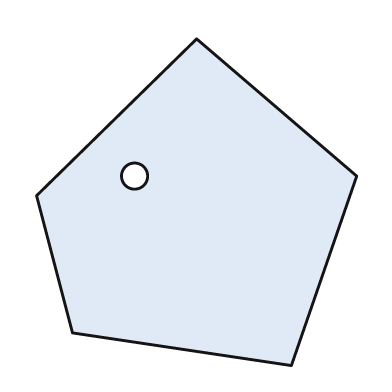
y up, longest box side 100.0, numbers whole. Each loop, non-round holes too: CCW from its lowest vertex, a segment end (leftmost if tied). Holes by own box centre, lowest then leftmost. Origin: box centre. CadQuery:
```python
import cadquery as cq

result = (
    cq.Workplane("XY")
    .moveTo(29.0, -50.0)
    .lineTo(49.0, 8.0)
    .lineTo(0.0, 50.0)
    .lineTo(-49.0, 2.0)
    .lineTo(-38.0, -40.0)
    .close()
    .moveTo(-19.0, 8.0)
    .circle(4.0)
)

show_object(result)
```